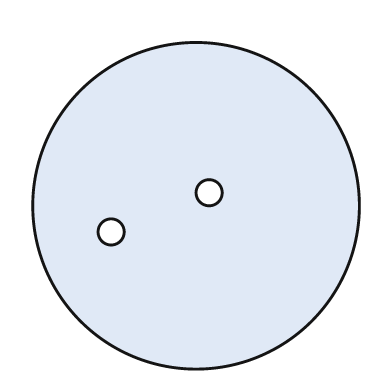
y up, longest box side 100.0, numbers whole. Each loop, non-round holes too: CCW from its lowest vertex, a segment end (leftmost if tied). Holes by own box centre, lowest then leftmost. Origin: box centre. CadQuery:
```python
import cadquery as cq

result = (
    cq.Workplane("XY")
    .moveTo(0.0, 0.0)
    .circle(50.0)
    .moveTo(-26.0, -8.0)
    .circle(4.0)
    .moveTo(4.0, 4.0)
    .circle(4.0)
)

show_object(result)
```